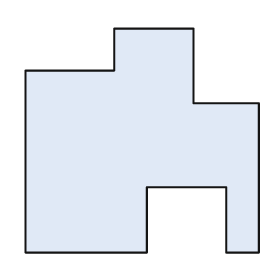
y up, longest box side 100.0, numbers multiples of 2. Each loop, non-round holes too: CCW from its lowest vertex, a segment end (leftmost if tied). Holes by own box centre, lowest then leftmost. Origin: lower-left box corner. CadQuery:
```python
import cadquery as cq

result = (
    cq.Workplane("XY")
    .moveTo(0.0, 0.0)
    .lineTo(52.0, 0.0)
    .lineTo(52.0, 28.0)
    .lineTo(86.0, 28.0)
    .lineTo(86.0, 0.0)
    .lineTo(100.0, 0.0)
    .lineTo(100.0, 64.0)
    .lineTo(72.0, 64.0)
    .lineTo(72.0, 96.0)
    .lineTo(38.0, 96.0)
    .lineTo(38.0, 78.0)
    .lineTo(0.0, 78.0)
    .close()
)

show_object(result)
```